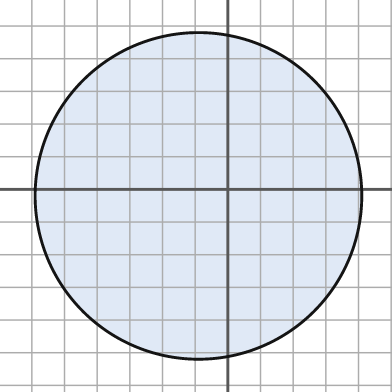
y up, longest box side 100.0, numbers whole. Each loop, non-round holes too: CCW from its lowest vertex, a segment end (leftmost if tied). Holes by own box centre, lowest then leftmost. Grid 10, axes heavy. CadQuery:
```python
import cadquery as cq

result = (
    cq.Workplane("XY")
    .moveTo(-9.0, -2.0)
    .circle(50.0)
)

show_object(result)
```